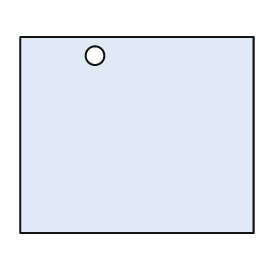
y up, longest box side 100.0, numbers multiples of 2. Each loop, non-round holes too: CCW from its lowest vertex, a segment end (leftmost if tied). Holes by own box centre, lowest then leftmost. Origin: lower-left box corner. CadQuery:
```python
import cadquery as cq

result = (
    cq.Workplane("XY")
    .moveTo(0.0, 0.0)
    .lineTo(100.0, 0.0)
    .lineTo(100.0, 84.0)
    .lineTo(0.0, 84.0)
    .close()
    .moveTo(32.0, 76.0)
    .circle(4.0)
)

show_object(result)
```